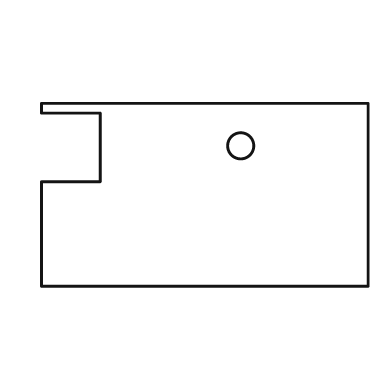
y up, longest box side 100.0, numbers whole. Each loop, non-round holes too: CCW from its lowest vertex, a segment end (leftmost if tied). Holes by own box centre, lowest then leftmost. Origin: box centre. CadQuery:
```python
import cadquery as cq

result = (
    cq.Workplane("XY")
    .moveTo(-50.0, -28.0)
    .lineTo(50.0, -28.0)
    .lineTo(50.0, 28.0)
    .lineTo(-50.0, 28.0)
    .lineTo(-50.0, 25.0)
    .lineTo(-32.0, 25.0)
    .lineTo(-32.0, 4.0)
    .lineTo(-50.0, 4.0)
    .close()
    .moveTo(11.0, 15.0)
    .circle(4.0)
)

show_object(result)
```